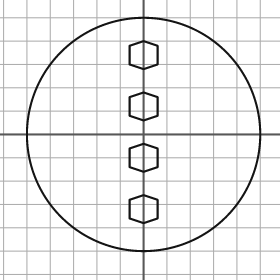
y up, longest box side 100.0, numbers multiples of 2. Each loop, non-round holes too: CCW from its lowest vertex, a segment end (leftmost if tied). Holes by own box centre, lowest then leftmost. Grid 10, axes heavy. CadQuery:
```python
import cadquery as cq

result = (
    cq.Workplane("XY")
    .moveTo(0.0, 0.0)
    .circle(50.0)
    .moveTo(0.0, -38.0)
    .lineTo(6.0, -36.0)
    .lineTo(6.0, -28.0)
    .lineTo(0.0, -26.0)
    .lineTo(-6.0, -28.0)
    .lineTo(-6.0, -36.0)
    .close()
    .moveTo(0.0, -16.0)
    .lineTo(6.0, -14.0)
    .lineTo(6.0, -6.0)
    .lineTo(0.0, -4.0)
    .lineTo(-6.0, -6.0)
    .lineTo(-6.0, -14.0)
    .close()
    .moveTo(0.0, 6.0)
    .lineTo(6.0, 8.0)
    .lineTo(6.0, 16.0)
    .lineTo(0.0, 18.0)
    .lineTo(-6.0, 16.0)
    .lineTo(-6.0, 8.0)
    .close()
    .moveTo(0.0, 28.0)
    .lineTo(6.0, 30.0)
    .lineTo(6.0, 38.0)
    .lineTo(0.0, 40.0)
    .lineTo(-6.0, 38.0)
    .lineTo(-6.0, 30.0)
    .close()
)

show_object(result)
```